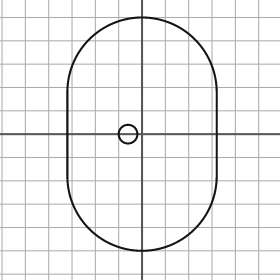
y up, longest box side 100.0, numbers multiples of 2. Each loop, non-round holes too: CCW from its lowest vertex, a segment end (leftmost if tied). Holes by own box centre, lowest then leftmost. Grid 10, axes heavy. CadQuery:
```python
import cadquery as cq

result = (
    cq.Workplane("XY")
    .moveTo(-32.0, -18.0)
    .threePointArc((0.0, -50.0), (32.0, -18.0))
    .lineTo(32.0, 18.0)
    .threePointArc((0.0, 50.0), (-32.0, 18.0))
    .close()
    .moveTo(-6.0, 0.0)
    .circle(4.0)
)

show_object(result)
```